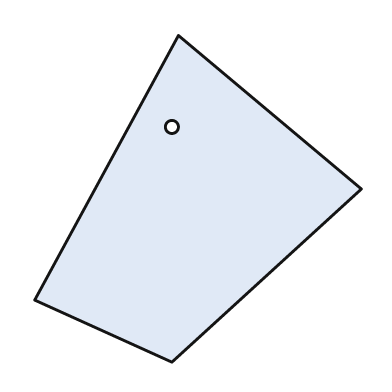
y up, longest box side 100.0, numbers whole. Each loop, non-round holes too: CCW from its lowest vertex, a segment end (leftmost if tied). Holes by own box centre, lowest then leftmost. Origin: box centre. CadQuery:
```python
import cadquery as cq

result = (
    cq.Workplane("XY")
    .moveTo(-8.0, -50.0)
    .lineTo(50.0, 3.0)
    .lineTo(-6.0, 50.0)
    .lineTo(-50.0, -31.0)
    .close()
    .moveTo(-8.0, 22.0)
    .circle(2.0)
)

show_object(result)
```